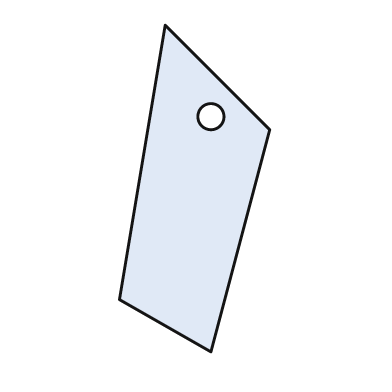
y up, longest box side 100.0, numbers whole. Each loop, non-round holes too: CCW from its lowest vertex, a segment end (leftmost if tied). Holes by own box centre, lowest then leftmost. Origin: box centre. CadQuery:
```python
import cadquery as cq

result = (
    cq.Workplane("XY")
    .moveTo(5.0, -50.0)
    .lineTo(23.0, 18.0)
    .lineTo(-9.0, 50.0)
    .lineTo(-23.0, -34.0)
    .close()
    .moveTo(5.0, 22.0)
    .circle(4.0)
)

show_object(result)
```